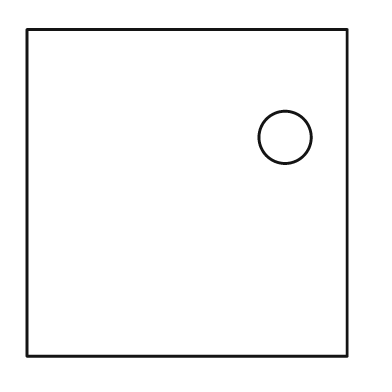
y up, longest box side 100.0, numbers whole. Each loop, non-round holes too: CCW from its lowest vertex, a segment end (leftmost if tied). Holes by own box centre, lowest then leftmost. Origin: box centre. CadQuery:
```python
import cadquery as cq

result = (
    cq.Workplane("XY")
    .moveTo(-49.0, -50.0)
    .lineTo(49.0, -50.0)
    .lineTo(49.0, 50.0)
    .lineTo(-49.0, 50.0)
    .close()
    .moveTo(30.0, 17.0)
    .circle(8.0)
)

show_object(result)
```